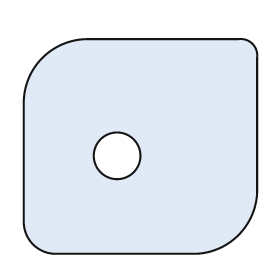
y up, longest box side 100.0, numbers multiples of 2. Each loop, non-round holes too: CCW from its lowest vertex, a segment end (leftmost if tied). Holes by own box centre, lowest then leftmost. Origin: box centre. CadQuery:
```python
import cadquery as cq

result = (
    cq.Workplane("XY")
    .moveTo(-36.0, -46.0)
    .lineTo(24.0, -46.0)
    .threePointArc((42.0, -38.0), (50.0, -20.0))
    .lineTo(50.0, 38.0)
    .threePointArc((48.0, 44.0), (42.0, 46.0))
    .lineTo(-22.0, 46.0)
    .threePointArc((-42.0, 38.0), (-50.0, 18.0))
    .lineTo(-50.0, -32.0)
    .threePointArc((-46.0, -42.0), (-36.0, -46.0))
    .close()
    .moveTo(-10.0, -4.0)
    .circle(10.0)
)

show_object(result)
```